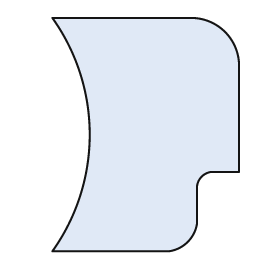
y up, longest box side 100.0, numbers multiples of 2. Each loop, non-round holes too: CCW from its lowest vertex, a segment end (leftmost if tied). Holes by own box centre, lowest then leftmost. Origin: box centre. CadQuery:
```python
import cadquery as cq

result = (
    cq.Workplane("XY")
    .moveTo(-40.0, -50.0)
    .lineTo(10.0, -50.0)
    .threePointArc((18.0, -46.0), (22.0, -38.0))
    .lineTo(22.0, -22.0)
    .threePointArc((24.0, -18.0), (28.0, -16.0))
    .lineTo(40.0, -16.0)
    .lineTo(40.0, 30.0)
    .threePointArc((34.0, 44.0), (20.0, 50.0))
    .lineTo(-40.0, 50.0)
    .threePointArc((-24.0, 0.0), (-40.0, -50.0))
    .close()
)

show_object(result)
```